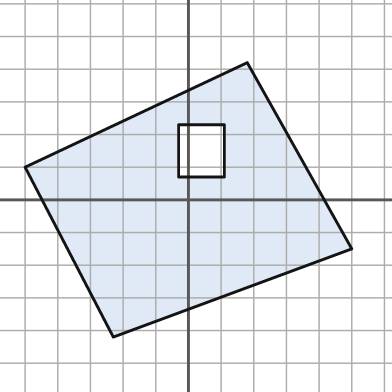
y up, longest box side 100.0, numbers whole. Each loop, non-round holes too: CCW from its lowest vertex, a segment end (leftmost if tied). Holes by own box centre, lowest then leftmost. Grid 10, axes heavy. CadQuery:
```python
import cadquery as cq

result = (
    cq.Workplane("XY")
    .moveTo(-23.0, -42.0)
    .lineTo(50.0, -15.0)
    .lineTo(18.0, 42.0)
    .lineTo(-50.0, 10.0)
    .close()
    .moveTo(-3.0, 7.0)
    .lineTo(11.0, 7.0)
    .lineTo(11.0, 23.0)
    .lineTo(-3.0, 23.0)
    .close()
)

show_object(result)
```